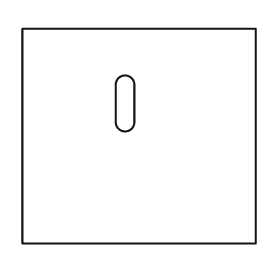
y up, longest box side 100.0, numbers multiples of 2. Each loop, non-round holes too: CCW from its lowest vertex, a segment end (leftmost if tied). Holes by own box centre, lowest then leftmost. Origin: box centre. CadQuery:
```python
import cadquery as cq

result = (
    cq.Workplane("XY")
    .moveTo(-50.0, -46.0)
    .lineTo(50.0, -46.0)
    .lineTo(50.0, 46.0)
    .lineTo(-50.0, 46.0)
    .close()
    .moveTo(-10.0, 6.0)
    .threePointArc((-6.0, 2.0), (-2.0, 6.0))
    .lineTo(-2.0, 22.0)
    .threePointArc((-6.0, 26.0), (-10.0, 22.0))
    .close()
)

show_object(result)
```